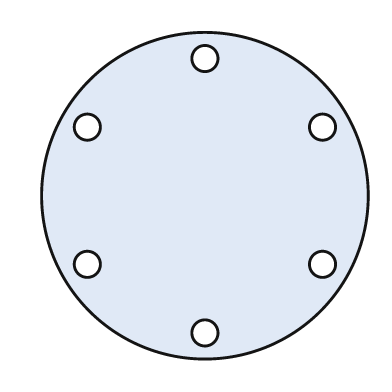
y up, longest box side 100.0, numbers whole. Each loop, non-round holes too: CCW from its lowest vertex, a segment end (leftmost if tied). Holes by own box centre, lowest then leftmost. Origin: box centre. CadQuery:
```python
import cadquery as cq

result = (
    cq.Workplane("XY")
    .moveTo(0.0, 0.0)
    .circle(50.0)
    .moveTo(0.0, -42.0)
    .circle(4.0)
    .moveTo(-36.0, -21.0)
    .circle(4.0)
    .moveTo(36.0, -21.0)
    .circle(4.0)
    .moveTo(-36.0, 21.0)
    .circle(4.0)
    .moveTo(36.0, 21.0)
    .circle(4.0)
    .moveTo(0.0, 42.0)
    .circle(4.0)
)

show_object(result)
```